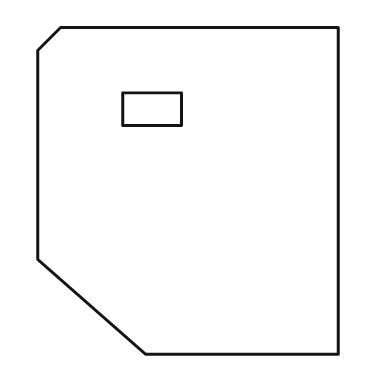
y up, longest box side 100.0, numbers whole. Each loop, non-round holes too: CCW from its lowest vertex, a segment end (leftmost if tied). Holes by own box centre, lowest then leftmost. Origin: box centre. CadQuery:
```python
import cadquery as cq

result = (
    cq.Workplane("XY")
    .moveTo(-13.0, -50.0)
    .lineTo(46.0, -50.0)
    .lineTo(46.0, 50.0)
    .lineTo(-39.0, 50.0)
    .lineTo(-46.0, 43.0)
    .lineTo(-46.0, -21.0)
    .close()
    .moveTo(-20.0, 20.0)
    .lineTo(-2.0, 20.0)
    .lineTo(-2.0, 30.0)
    .lineTo(-20.0, 30.0)
    .close()
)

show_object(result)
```